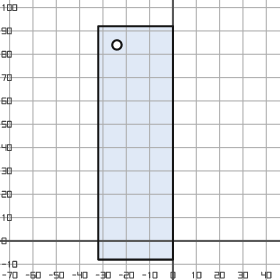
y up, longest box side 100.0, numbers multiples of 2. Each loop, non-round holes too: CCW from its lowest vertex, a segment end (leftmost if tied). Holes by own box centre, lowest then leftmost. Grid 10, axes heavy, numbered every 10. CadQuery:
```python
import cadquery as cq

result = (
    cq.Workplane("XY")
    .moveTo(-32.0, -8.0)
    .lineTo(0.0, -8.0)
    .lineTo(0.0, 92.0)
    .lineTo(-32.0, 92.0)
    .close()
    .moveTo(-24.0, 84.0)
    .circle(2.0)
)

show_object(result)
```